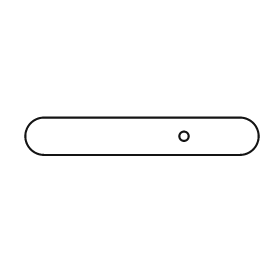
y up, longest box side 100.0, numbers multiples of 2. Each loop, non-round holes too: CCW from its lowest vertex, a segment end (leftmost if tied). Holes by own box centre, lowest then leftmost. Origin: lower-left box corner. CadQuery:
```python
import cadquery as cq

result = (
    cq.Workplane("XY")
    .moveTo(8.0, 0.0)
    .lineTo(92.0, 0.0)
    .threePointArc((100.0, 8.0), (92.0, 16.0))
    .lineTo(8.0, 16.0)
    .threePointArc((0.0, 8.0), (8.0, 0.0))
    .close()
    .moveTo(68.0, 8.0)
    .circle(2.0)
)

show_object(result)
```